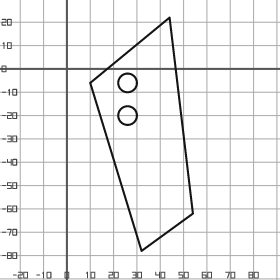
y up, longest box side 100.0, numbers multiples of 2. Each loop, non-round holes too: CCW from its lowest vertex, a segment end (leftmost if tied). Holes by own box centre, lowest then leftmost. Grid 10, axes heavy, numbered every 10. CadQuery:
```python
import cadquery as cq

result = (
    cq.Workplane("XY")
    .moveTo(32.0, -78.0)
    .lineTo(54.0, -62.0)
    .lineTo(44.0, 22.0)
    .lineTo(10.0, -6.0)
    .close()
    .moveTo(26.0, -20.0)
    .circle(4.0)
    .moveTo(26.0, -6.0)
    .circle(4.0)
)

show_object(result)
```